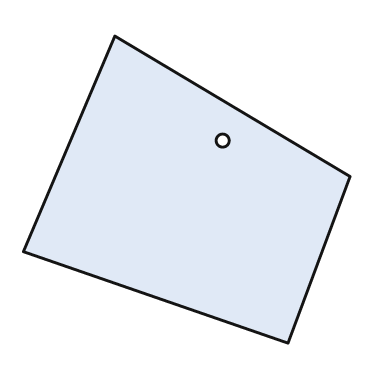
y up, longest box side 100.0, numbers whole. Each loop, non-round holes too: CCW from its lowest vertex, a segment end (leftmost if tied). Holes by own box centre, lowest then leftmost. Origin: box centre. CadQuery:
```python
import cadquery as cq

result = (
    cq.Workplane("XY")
    .moveTo(31.0, -47.0)
    .lineTo(50.0, 4.0)
    .lineTo(-22.0, 47.0)
    .lineTo(-50.0, -19.0)
    .close()
    .moveTo(11.0, 15.0)
    .circle(2.0)
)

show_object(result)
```